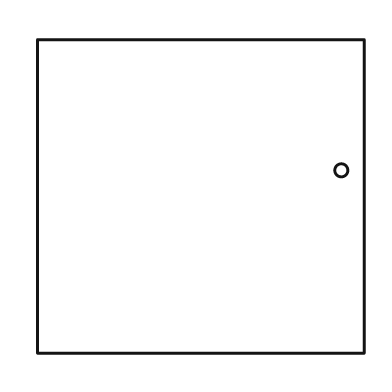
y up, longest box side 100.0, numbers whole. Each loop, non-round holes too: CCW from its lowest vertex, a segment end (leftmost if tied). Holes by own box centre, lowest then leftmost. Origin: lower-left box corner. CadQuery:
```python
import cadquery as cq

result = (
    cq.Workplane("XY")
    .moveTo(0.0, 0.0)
    .lineTo(100.0, 0.0)
    .lineTo(100.0, 96.0)
    .lineTo(0.0, 96.0)
    .close()
    .moveTo(93.0, 56.0)
    .circle(2.0)
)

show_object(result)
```